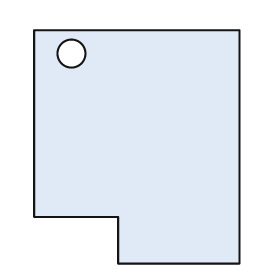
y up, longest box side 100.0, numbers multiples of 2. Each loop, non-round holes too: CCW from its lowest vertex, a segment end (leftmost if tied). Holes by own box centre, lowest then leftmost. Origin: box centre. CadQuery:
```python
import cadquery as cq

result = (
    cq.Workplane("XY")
    .moveTo(-8.0, -50.0)
    .lineTo(44.0, -50.0)
    .lineTo(44.0, 50.0)
    .lineTo(-44.0, 50.0)
    .lineTo(-44.0, -30.0)
    .lineTo(-8.0, -30.0)
    .close()
    .moveTo(-28.0, 40.0)
    .circle(6.0)
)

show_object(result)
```